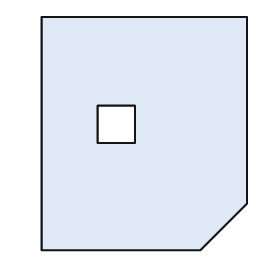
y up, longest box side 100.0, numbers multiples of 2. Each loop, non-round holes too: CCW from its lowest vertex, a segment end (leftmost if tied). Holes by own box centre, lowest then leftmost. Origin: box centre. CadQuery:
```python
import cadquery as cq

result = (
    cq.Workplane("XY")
    .moveTo(-44.0, -50.0)
    .lineTo(24.0, -50.0)
    .lineTo(44.0, -30.0)
    .lineTo(44.0, 50.0)
    .lineTo(-44.0, 50.0)
    .close()
    .moveTo(-20.0, -4.0)
    .lineTo(-4.0, -4.0)
    .lineTo(-4.0, 12.0)
    .lineTo(-20.0, 12.0)
    .close()
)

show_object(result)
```